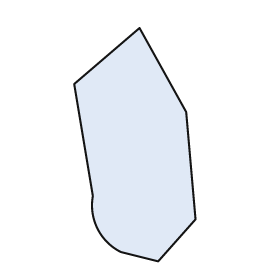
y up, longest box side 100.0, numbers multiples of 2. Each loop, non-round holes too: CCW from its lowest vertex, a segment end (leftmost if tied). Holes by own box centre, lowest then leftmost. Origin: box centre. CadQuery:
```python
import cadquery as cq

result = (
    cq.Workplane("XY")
    .moveTo(10.0, -50.0)
    .lineTo(26.0, -32.0)
    .lineTo(22.0, 14.0)
    .lineTo(2.0, 50.0)
    .lineTo(-26.0, 26.0)
    .lineTo(-18.0, -22.0)
    .threePointArc((-16.0, -36.0), (-6.0, -46.0))
    .close()
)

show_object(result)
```